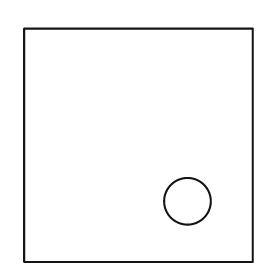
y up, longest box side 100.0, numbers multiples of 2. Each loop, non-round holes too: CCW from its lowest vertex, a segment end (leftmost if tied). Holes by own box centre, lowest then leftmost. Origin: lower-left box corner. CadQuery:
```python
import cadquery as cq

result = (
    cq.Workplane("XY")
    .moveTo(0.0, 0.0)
    .lineTo(98.0, 0.0)
    .lineTo(98.0, 100.0)
    .lineTo(0.0, 100.0)
    .close()
    .moveTo(70.0, 26.0)
    .circle(10.0)
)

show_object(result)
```